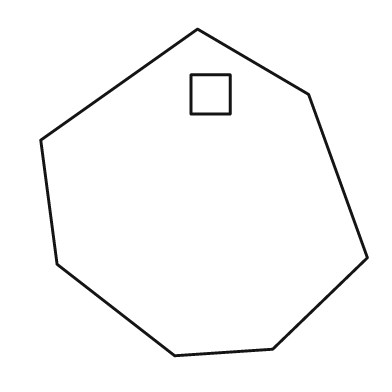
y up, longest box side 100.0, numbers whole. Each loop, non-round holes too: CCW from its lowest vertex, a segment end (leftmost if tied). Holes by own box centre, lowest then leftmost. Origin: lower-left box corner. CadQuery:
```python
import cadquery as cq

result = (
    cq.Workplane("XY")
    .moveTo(41.0, 0.0)
    .lineTo(71.0, 2.0)
    .lineTo(100.0, 30.0)
    .lineTo(82.0, 80.0)
    .lineTo(48.0, 100.0)
    .lineTo(0.0, 66.0)
    .lineTo(5.0, 28.0)
    .close()
    .moveTo(46.0, 74.0)
    .lineTo(58.0, 74.0)
    .lineTo(58.0, 86.0)
    .lineTo(46.0, 86.0)
    .close()
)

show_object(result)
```